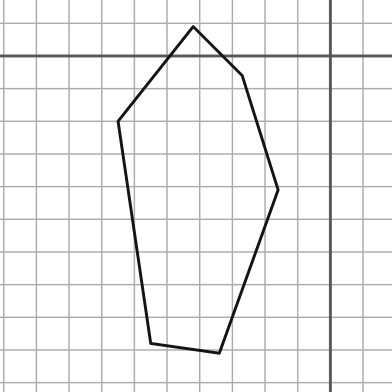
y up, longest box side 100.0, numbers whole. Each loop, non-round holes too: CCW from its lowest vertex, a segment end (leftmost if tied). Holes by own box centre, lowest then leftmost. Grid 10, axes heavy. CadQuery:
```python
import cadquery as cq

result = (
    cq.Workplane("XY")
    .moveTo(-34.0, -91.0)
    .lineTo(-16.0, -41.0)
    .lineTo(-27.0, -6.0)
    .lineTo(-42.0, 9.0)
    .lineTo(-65.0, -20.0)
    .lineTo(-55.0, -88.0)
    .close()
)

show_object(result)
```